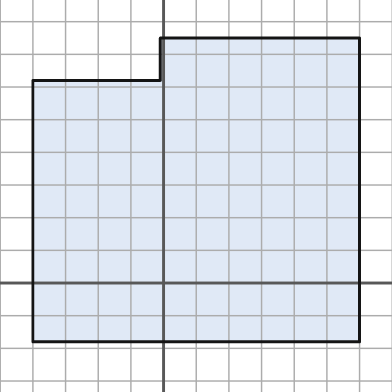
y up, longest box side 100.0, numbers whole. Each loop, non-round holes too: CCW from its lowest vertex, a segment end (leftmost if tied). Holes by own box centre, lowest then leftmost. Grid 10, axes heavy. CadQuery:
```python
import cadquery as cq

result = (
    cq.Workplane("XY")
    .moveTo(-40.0, -18.0)
    .lineTo(60.0, -18.0)
    .lineTo(60.0, 75.0)
    .lineTo(-1.0, 75.0)
    .lineTo(-1.0, 62.0)
    .lineTo(-40.0, 62.0)
    .close()
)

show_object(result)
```